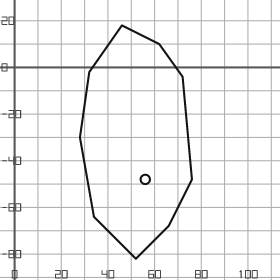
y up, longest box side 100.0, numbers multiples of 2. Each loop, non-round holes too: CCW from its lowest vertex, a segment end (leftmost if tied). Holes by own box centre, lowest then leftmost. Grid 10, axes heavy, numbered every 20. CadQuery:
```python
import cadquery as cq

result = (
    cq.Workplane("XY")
    .moveTo(52.0, -82.0)
    .lineTo(66.0, -68.0)
    .lineTo(76.0, -48.0)
    .lineTo(72.0, -4.0)
    .lineTo(62.0, 10.0)
    .lineTo(46.0, 18.0)
    .lineTo(32.0, -2.0)
    .lineTo(28.0, -30.0)
    .lineTo(34.0, -64.0)
    .close()
    .moveTo(56.0, -48.0)
    .circle(2.0)
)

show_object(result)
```